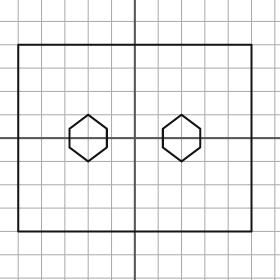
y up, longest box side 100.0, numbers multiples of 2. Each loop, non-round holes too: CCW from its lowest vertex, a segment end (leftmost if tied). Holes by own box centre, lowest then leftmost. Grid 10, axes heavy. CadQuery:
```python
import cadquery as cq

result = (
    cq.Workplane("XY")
    .moveTo(-50.0, -40.0)
    .lineTo(50.0, -40.0)
    .lineTo(50.0, 40.0)
    .lineTo(-50.0, 40.0)
    .close()
    .moveTo(-20.0, -10.0)
    .lineTo(-12.0, -4.0)
    .lineTo(-12.0, 4.0)
    .lineTo(-20.0, 10.0)
    .lineTo(-28.0, 4.0)
    .lineTo(-28.0, -4.0)
    .close()
    .moveTo(20.0, -10.0)
    .lineTo(28.0, -4.0)
    .lineTo(28.0, 4.0)
    .lineTo(20.0, 10.0)
    .lineTo(12.0, 4.0)
    .lineTo(12.0, -4.0)
    .close()
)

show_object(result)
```